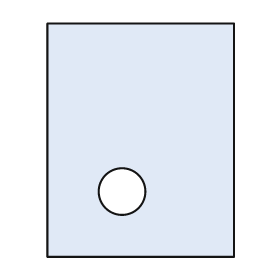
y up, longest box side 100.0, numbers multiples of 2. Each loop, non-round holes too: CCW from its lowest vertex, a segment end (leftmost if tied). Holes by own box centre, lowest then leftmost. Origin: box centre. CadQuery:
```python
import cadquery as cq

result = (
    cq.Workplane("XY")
    .moveTo(-40.0, -50.0)
    .lineTo(40.0, -50.0)
    .lineTo(40.0, 50.0)
    .lineTo(-40.0, 50.0)
    .close()
    .moveTo(-8.0, -22.0)
    .circle(10.0)
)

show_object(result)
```